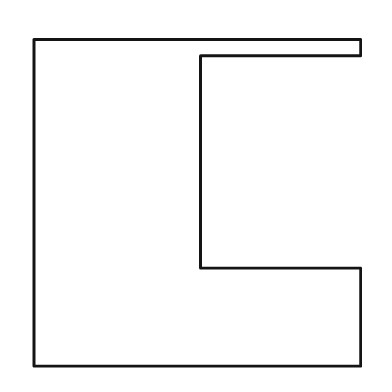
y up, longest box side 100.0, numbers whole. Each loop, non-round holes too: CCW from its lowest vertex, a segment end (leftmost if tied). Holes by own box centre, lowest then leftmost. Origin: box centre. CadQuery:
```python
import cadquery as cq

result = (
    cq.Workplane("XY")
    .moveTo(-50.0, -50.0)
    .lineTo(50.0, -50.0)
    .lineTo(50.0, -20.0)
    .lineTo(1.0, -20.0)
    .lineTo(1.0, 45.0)
    .lineTo(50.0, 45.0)
    .lineTo(50.0, 50.0)
    .lineTo(-50.0, 50.0)
    .close()
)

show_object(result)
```